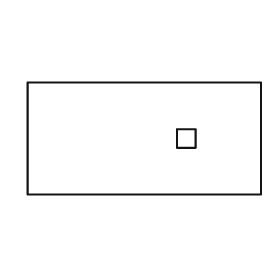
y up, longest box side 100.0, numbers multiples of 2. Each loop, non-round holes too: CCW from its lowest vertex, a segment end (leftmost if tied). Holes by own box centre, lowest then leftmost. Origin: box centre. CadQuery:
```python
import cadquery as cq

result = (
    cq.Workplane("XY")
    .moveTo(-50.0, -24.0)
    .lineTo(50.0, -24.0)
    .lineTo(50.0, 24.0)
    .lineTo(-50.0, 24.0)
    .close()
    .moveTo(14.0, -4.0)
    .lineTo(22.0, -4.0)
    .lineTo(22.0, 4.0)
    .lineTo(14.0, 4.0)
    .close()
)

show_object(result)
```